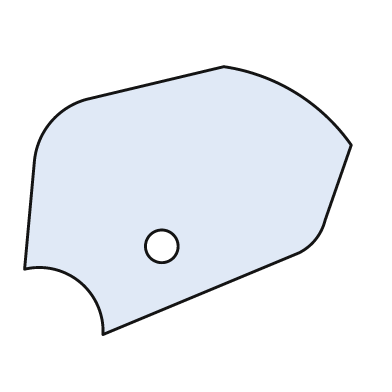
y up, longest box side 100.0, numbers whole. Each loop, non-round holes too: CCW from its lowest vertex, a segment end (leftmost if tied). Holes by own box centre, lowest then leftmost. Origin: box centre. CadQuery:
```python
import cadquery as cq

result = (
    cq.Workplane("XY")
    .moveTo(-26.0, -41.0)
    .lineTo(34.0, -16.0)
    .threePointArc((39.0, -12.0), (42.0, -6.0))
    .lineTo(50.0, 17.0)
    .threePointArc((33.0, 33.0), (11.0, 41.0))
    .lineTo(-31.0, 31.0)
    .threePointArc((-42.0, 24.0), (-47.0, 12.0))
    .lineTo(-50.0, -21.0)
    .threePointArc((-33.0, -25.0), (-26.0, -41.0))
    .close()
    .moveTo(-8.0, -14.0)
    .circle(5.0)
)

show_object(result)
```